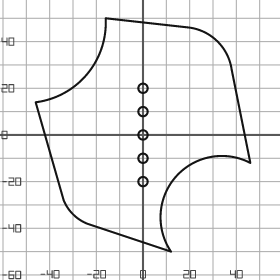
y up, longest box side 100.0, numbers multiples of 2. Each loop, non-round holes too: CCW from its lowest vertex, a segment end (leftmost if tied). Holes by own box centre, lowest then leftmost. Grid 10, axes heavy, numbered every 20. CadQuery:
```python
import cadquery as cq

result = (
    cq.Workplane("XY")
    .moveTo(12.0, -50.0)
    .threePointArc((14.0, -18.0), (46.0, -12.0))
    .lineTo(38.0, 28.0)
    .threePointArc((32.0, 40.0), (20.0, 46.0))
    .lineTo(-16.0, 50.0)
    .threePointArc((-24.0, 26.0), (-46.0, 14.0))
    .lineTo(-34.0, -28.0)
    .threePointArc((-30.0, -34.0), (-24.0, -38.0))
    .close()
    .moveTo(0.0, -20.0)
    .circle(2.0)
    .moveTo(0.0, -10.0)
    .circle(2.0)
    .moveTo(0.0, 0.0)
    .circle(2.0)
    .moveTo(0.0, 10.0)
    .circle(2.0)
    .moveTo(0.0, 20.0)
    .circle(2.0)
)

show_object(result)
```